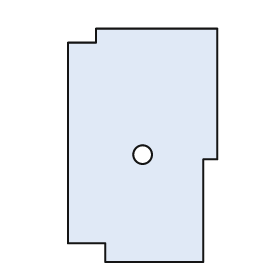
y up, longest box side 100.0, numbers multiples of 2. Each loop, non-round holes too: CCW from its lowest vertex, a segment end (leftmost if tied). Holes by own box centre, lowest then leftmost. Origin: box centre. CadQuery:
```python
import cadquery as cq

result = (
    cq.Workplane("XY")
    .moveTo(-16.0, -50.0)
    .lineTo(26.0, -50.0)
    .lineTo(26.0, -6.0)
    .lineTo(32.0, -6.0)
    .lineTo(32.0, 50.0)
    .lineTo(-20.0, 50.0)
    .lineTo(-20.0, 44.0)
    .lineTo(-32.0, 44.0)
    .lineTo(-32.0, -42.0)
    .lineTo(-16.0, -42.0)
    .close()
    .moveTo(0.0, -4.0)
    .circle(4.0)
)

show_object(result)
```